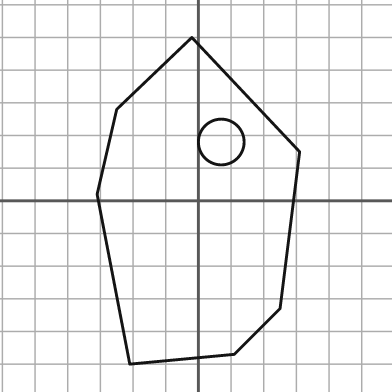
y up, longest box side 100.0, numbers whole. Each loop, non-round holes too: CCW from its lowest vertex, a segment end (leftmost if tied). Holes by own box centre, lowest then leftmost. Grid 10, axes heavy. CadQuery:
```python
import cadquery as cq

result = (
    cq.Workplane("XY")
    .moveTo(-21.0, -50.0)
    .lineTo(11.0, -47.0)
    .lineTo(25.0, -33.0)
    .lineTo(31.0, 15.0)
    .lineTo(-2.0, 50.0)
    .lineTo(-25.0, 28.0)
    .lineTo(-31.0, 2.0)
    .close()
    .moveTo(7.0, 18.0)
    .circle(7.0)
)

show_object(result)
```